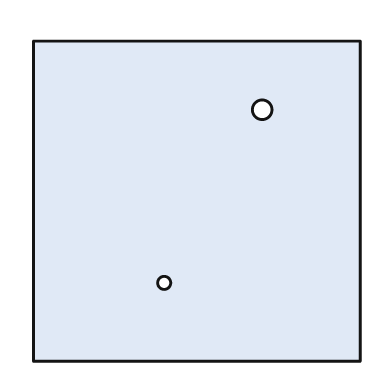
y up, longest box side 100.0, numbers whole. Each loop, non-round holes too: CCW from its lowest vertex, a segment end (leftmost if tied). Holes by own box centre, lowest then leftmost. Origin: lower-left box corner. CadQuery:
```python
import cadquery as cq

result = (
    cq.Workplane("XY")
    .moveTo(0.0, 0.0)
    .lineTo(100.0, 0.0)
    .lineTo(100.0, 98.0)
    .lineTo(0.0, 98.0)
    .close()
    .moveTo(40.0, 24.0)
    .circle(2.0)
    .moveTo(70.0, 77.0)
    .circle(3.0)
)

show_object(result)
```